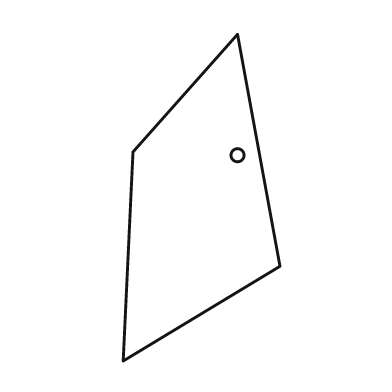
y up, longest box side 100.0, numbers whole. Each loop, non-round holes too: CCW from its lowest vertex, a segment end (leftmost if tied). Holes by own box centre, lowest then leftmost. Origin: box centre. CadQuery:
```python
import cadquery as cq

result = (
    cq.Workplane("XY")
    .moveTo(-24.0, -50.0)
    .lineTo(24.0, -21.0)
    .lineTo(11.0, 50.0)
    .lineTo(-21.0, 14.0)
    .close()
    .moveTo(11.0, 13.0)
    .circle(2.0)
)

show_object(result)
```